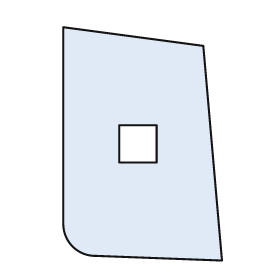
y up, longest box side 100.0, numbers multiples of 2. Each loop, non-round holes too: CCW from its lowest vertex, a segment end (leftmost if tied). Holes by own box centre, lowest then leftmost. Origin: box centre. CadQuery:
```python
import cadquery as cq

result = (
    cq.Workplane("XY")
    .moveTo(34.0, -50.0)
    .lineTo(26.0, 42.0)
    .lineTo(-34.0, 50.0)
    .lineTo(-34.0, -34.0)
    .threePointArc((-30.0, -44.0), (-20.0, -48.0))
    .close()
    .moveTo(-10.0, -8.0)
    .lineTo(6.0, -8.0)
    .lineTo(6.0, 8.0)
    .lineTo(-10.0, 8.0)
    .close()
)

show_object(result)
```